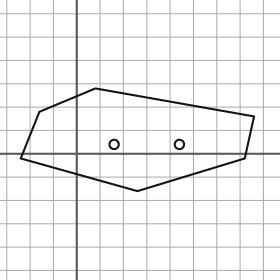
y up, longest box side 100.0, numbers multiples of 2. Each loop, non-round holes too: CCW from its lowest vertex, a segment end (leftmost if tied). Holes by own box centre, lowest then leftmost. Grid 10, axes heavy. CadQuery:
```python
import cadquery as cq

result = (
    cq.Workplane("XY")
    .moveTo(26.0, -16.0)
    .lineTo(72.0, -2.0)
    .lineTo(76.0, 16.0)
    .lineTo(8.0, 28.0)
    .lineTo(-16.0, 18.0)
    .lineTo(-24.0, -2.0)
    .close()
    .moveTo(16.0, 4.0)
    .circle(2.0)
    .moveTo(44.0, 4.0)
    .circle(2.0)
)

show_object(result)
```